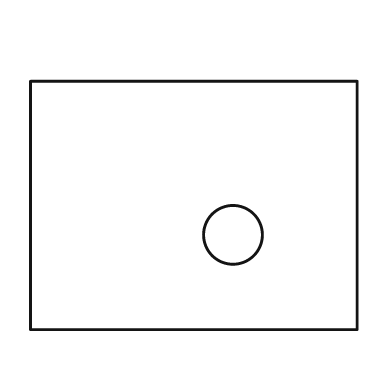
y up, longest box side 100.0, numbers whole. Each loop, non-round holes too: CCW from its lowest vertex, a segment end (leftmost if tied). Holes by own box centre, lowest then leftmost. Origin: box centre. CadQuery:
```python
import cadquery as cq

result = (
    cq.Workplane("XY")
    .moveTo(-50.0, -38.0)
    .lineTo(50.0, -38.0)
    .lineTo(50.0, 38.0)
    .lineTo(-50.0, 38.0)
    .close()
    .moveTo(12.0, -9.0)
    .circle(9.0)
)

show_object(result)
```